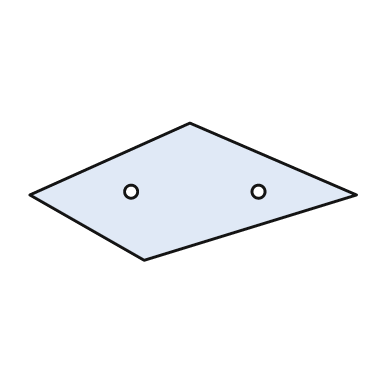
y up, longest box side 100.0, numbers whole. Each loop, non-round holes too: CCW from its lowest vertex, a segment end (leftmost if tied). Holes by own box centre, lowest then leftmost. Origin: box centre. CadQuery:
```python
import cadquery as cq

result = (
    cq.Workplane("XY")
    .moveTo(-15.0, -21.0)
    .lineTo(50.0, -1.0)
    .lineTo(-1.0, 21.0)
    .lineTo(-50.0, -1.0)
    .close()
    .moveTo(-19.0, 0.0)
    .circle(2.0)
    .moveTo(20.0, 0.0)
    .circle(2.0)
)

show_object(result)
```